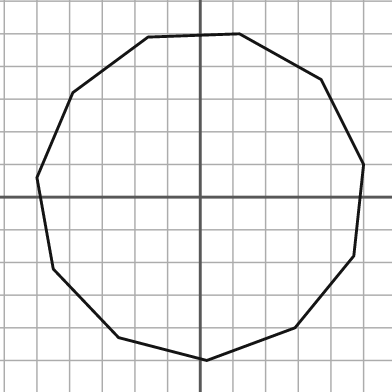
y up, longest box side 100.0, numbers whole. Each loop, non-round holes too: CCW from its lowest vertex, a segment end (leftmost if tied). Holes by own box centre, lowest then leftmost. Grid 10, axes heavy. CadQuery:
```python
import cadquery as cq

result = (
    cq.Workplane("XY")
    .moveTo(2.0, -50.0)
    .lineTo(29.0, -40.0)
    .lineTo(47.0, -18.0)
    .lineTo(50.0, 10.0)
    .lineTo(37.0, 36.0)
    .lineTo(12.0, 50.0)
    .lineTo(-16.0, 49.0)
    .lineTo(-39.0, 32.0)
    .lineTo(-50.0, 6.0)
    .lineTo(-45.0, -22.0)
    .lineTo(-25.0, -43.0)
    .close()
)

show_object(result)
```